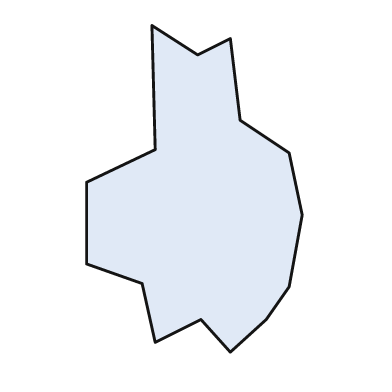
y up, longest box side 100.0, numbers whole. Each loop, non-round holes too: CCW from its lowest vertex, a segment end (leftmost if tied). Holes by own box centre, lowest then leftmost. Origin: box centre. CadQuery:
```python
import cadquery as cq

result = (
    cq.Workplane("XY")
    .moveTo(11.0, -50.0)
    .lineTo(22.0, -40.0)
    .lineTo(29.0, -30.0)
    .lineTo(33.0, -8.0)
    .lineTo(29.0, 11.0)
    .lineTo(14.0, 21.0)
    .lineTo(11.0, 46.0)
    .lineTo(1.0, 41.0)
    .lineTo(-13.0, 50.0)
    .lineTo(-12.0, 12.0)
    .lineTo(-33.0, 2.0)
    .lineTo(-33.0, -23.0)
    .lineTo(-16.0, -29.0)
    .lineTo(-12.0, -47.0)
    .lineTo(2.0, -40.0)
    .close()
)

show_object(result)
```